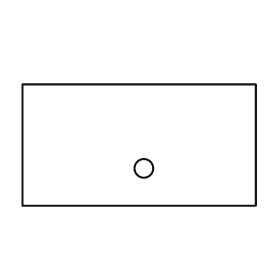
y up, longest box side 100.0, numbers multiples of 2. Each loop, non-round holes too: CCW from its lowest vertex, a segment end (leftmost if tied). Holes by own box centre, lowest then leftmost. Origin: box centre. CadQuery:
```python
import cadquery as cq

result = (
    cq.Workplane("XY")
    .moveTo(-50.0, -26.0)
    .lineTo(50.0, -26.0)
    .lineTo(50.0, 26.0)
    .lineTo(-50.0, 26.0)
    .close()
    .moveTo(2.0, -10.0)
    .circle(4.0)
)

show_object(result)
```